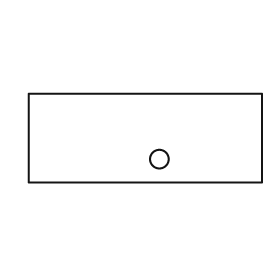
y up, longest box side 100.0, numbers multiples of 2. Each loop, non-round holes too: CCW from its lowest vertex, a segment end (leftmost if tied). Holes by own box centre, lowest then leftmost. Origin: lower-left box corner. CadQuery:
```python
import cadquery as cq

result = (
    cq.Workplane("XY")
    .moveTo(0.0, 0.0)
    .lineTo(100.0, 0.0)
    .lineTo(100.0, 38.0)
    .lineTo(0.0, 38.0)
    .close()
    .moveTo(56.0, 10.0)
    .circle(4.0)
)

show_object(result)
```